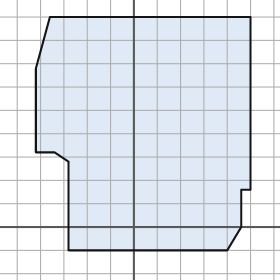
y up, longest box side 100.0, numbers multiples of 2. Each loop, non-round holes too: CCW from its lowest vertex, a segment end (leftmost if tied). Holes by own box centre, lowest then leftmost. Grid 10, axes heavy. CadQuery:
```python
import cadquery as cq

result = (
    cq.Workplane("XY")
    .moveTo(-28.0, -10.0)
    .lineTo(40.0, -10.0)
    .lineTo(46.0, 0.0)
    .lineTo(46.0, 16.0)
    .lineTo(50.0, 16.0)
    .lineTo(50.0, 90.0)
    .lineTo(-36.0, 90.0)
    .lineTo(-42.0, 68.0)
    .lineTo(-42.0, 32.0)
    .lineTo(-34.0, 32.0)
    .lineTo(-28.0, 28.0)
    .close()
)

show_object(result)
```